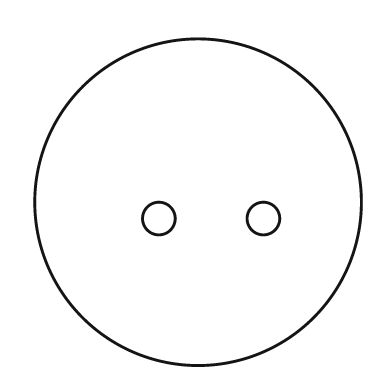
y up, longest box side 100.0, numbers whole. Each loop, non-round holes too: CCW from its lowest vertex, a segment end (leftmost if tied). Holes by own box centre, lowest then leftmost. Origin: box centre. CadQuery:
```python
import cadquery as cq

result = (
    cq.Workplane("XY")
    .moveTo(0.0, 0.0)
    .circle(50.0)
    .moveTo(-12.0, -5.0)
    .circle(5.0)
    .moveTo(20.0, -5.0)
    .circle(5.0)
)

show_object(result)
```